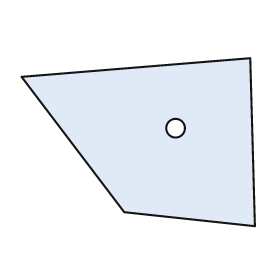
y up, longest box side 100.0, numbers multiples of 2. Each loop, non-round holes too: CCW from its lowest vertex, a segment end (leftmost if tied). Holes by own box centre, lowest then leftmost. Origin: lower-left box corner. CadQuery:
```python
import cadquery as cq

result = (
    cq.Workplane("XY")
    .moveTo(100.0, 0.0)
    .lineTo(98.0, 72.0)
    .lineTo(0.0, 64.0)
    .lineTo(44.0, 6.0)
    .close()
    .moveTo(66.0, 42.0)
    .circle(4.0)
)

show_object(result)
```